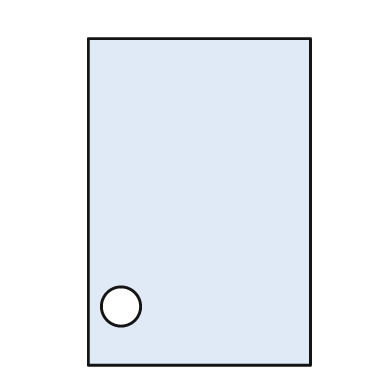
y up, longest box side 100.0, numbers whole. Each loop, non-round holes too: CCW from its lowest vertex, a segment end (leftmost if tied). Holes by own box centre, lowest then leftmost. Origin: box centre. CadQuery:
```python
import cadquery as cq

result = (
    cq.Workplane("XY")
    .moveTo(-34.0, -50.0)
    .lineTo(34.0, -50.0)
    .lineTo(34.0, 50.0)
    .lineTo(-34.0, 50.0)
    .close()
    .moveTo(-24.0, -32.0)
    .circle(6.0)
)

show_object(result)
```